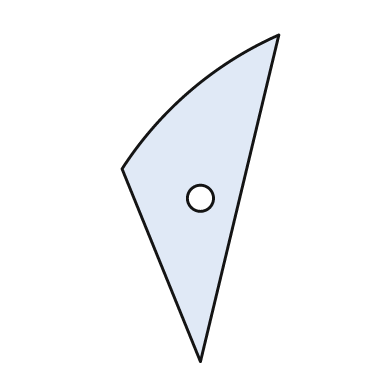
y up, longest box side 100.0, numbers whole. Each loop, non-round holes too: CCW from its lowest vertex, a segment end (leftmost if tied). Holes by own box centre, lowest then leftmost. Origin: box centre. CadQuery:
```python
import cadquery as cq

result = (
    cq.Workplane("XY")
    .moveTo(0.0, -50.0)
    .lineTo(24.0, 50.0)
    .threePointArc((-3.0, 33.0), (-24.0, 9.0))
    .close()
    .moveTo(0.0, 0.0)
    .circle(4.0)
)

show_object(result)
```